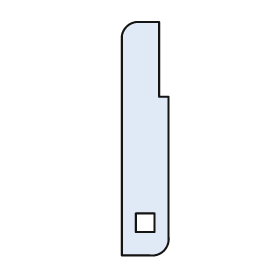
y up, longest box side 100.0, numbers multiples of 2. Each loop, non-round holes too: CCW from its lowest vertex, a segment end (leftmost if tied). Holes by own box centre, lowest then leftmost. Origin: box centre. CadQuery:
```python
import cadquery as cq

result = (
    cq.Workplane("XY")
    .moveTo(-10.0, -50.0)
    .lineTo(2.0, -50.0)
    .threePointArc((8.0, -48.0), (10.0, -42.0))
    .lineTo(10.0, 18.0)
    .lineTo(6.0, 18.0)
    .lineTo(6.0, 50.0)
    .lineTo(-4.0, 50.0)
    .threePointArc((-8.0, 48.0), (-10.0, 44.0))
    .close()
    .moveTo(-4.0, -40.0)
    .lineTo(4.0, -40.0)
    .lineTo(4.0, -32.0)
    .lineTo(-4.0, -32.0)
    .close()
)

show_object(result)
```